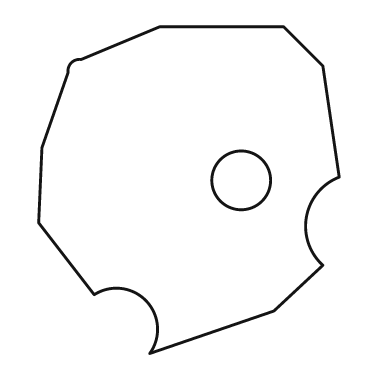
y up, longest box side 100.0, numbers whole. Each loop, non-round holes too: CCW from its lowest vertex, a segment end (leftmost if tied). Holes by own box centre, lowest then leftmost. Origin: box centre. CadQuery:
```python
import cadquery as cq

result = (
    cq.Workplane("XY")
    .moveTo(-12.0, -50.0)
    .lineTo(26.0, -37.0)
    .lineTo(41.0, -23.0)
    .threePointArc((36.0, -8.0), (46.0, 4.0))
    .lineTo(41.0, 38.0)
    .lineTo(29.0, 50.0)
    .lineTo(-9.0, 50.0)
    .lineTo(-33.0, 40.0)
    .threePointArc((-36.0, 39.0), (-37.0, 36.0))
    .lineTo(-45.0, 13.0)
    .lineTo(-46.0, -10.0)
    .lineTo(-29.0, -32.0)
    .threePointArc((-13.0, -34.0), (-12.0, -50.0))
    .close()
    .moveTo(16.0, 3.0)
    .circle(9.0)
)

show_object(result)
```